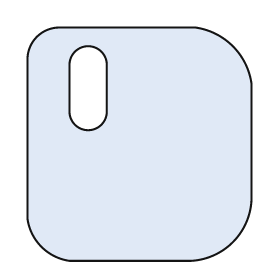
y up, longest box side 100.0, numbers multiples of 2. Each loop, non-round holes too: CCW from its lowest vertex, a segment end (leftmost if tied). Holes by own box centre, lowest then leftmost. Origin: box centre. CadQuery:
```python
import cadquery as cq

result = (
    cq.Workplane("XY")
    .moveTo(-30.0, -50.0)
    .lineTo(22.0, -50.0)
    .threePointArc((40.0, -42.0), (48.0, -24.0))
    .lineTo(48.0, 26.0)
    .threePointArc((40.0, 42.0), (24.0, 50.0))
    .lineTo(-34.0, 50.0)
    .threePointArc((-44.0, 46.0), (-48.0, 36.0))
    .lineTo(-48.0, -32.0)
    .threePointArc((-42.0, -44.0), (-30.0, -50.0))
    .close()
    .moveTo(-30.0, 14.0)
    .threePointArc((-22.0, 6.0), (-14.0, 14.0))
    .lineTo(-14.0, 34.0)
    .threePointArc((-22.0, 42.0), (-30.0, 34.0))
    .close()
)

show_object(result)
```